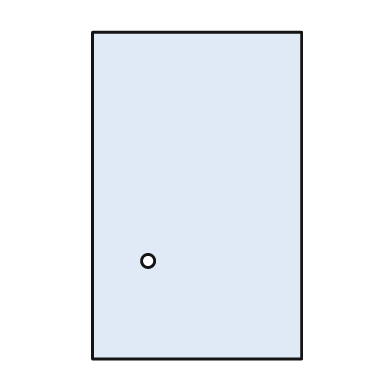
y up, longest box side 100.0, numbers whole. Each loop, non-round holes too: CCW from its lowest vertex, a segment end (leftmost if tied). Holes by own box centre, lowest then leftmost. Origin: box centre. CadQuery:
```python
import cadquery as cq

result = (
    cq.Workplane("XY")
    .moveTo(-32.0, -50.0)
    .lineTo(32.0, -50.0)
    .lineTo(32.0, 50.0)
    .lineTo(-32.0, 50.0)
    .close()
    .moveTo(-15.0, -20.0)
    .circle(2.0)
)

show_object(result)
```